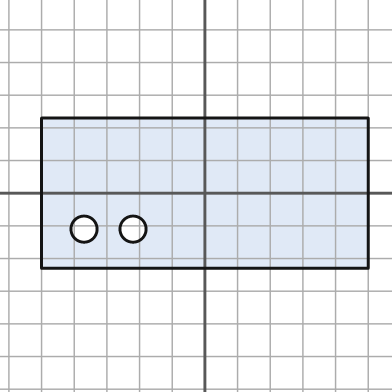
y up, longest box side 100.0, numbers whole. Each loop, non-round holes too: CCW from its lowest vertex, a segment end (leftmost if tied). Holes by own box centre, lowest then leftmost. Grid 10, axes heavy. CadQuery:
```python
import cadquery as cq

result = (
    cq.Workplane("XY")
    .moveTo(-50.0, -23.0)
    .lineTo(50.0, -23.0)
    .lineTo(50.0, 23.0)
    .lineTo(-50.0, 23.0)
    .close()
    .moveTo(-37.0, -11.0)
    .circle(4.0)
    .moveTo(-22.0, -11.0)
    .circle(4.0)
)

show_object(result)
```